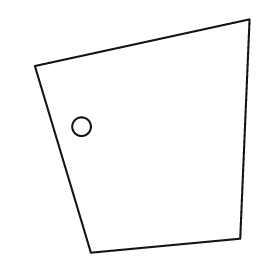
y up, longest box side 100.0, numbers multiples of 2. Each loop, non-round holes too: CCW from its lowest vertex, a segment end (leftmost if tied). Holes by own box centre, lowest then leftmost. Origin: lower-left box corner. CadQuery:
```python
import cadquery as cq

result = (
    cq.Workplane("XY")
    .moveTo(24.0, 0.0)
    .lineTo(88.0, 6.0)
    .lineTo(92.0, 100.0)
    .lineTo(0.0, 80.0)
    .close()
    .moveTo(20.0, 54.0)
    .circle(4.0)
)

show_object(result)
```